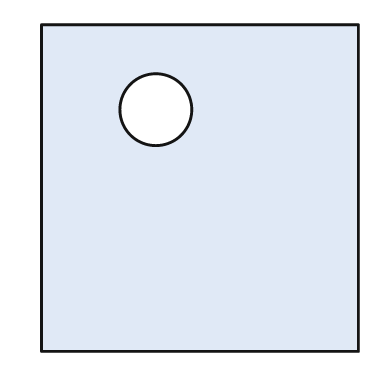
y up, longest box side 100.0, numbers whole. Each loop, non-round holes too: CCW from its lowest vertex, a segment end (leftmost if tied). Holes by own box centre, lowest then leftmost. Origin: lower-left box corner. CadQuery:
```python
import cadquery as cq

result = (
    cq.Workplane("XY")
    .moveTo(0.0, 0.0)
    .lineTo(97.0, 0.0)
    .lineTo(97.0, 100.0)
    .lineTo(0.0, 100.0)
    .close()
    .moveTo(35.0, 74.0)
    .circle(11.0)
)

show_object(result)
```